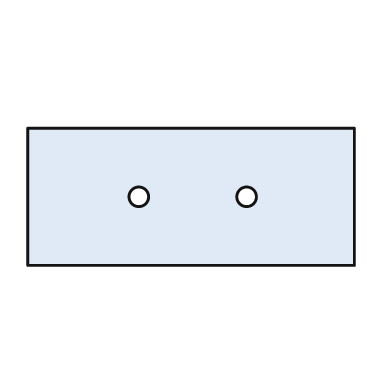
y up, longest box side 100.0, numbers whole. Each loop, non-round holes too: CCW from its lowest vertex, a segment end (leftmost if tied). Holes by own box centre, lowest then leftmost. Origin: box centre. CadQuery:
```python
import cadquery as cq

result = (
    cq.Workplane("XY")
    .moveTo(-50.0, -21.0)
    .lineTo(50.0, -21.0)
    .lineTo(50.0, 21.0)
    .lineTo(-50.0, 21.0)
    .close()
    .moveTo(-16.0, 0.0)
    .circle(3.0)
    .moveTo(17.0, 0.0)
    .circle(3.0)
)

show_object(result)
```